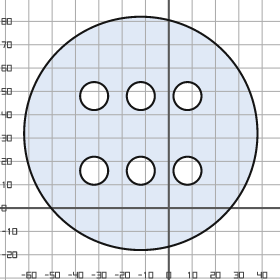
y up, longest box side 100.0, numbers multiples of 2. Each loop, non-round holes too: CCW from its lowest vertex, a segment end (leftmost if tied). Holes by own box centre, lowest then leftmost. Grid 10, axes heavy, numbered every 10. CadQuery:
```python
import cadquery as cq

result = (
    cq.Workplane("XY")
    .moveTo(-12.0, 32.0)
    .circle(50.0)
    .moveTo(-32.0, 16.0)
    .circle(6.0)
    .moveTo(-12.0, 16.0)
    .circle(6.0)
    .moveTo(8.0, 16.0)
    .circle(6.0)
    .moveTo(-32.0, 48.0)
    .circle(6.0)
    .moveTo(-12.0, 48.0)
    .circle(6.0)
    .moveTo(8.0, 48.0)
    .circle(6.0)
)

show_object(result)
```